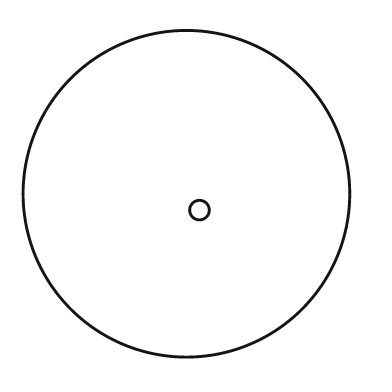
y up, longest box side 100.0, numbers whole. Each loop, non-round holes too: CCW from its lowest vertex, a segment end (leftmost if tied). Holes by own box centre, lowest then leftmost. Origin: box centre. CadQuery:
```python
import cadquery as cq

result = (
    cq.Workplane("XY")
    .moveTo(0.0, 0.0)
    .circle(50.0)
    .moveTo(4.0, -5.0)
    .circle(3.0)
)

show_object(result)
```